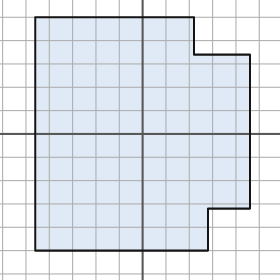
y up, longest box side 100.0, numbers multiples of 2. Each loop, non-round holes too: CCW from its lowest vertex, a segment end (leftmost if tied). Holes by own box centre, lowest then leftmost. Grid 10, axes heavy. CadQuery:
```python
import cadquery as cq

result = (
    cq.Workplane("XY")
    .moveTo(-46.0, -50.0)
    .lineTo(28.0, -50.0)
    .lineTo(28.0, -32.0)
    .lineTo(46.0, -32.0)
    .lineTo(46.0, 34.0)
    .lineTo(22.0, 34.0)
    .lineTo(22.0, 50.0)
    .lineTo(-46.0, 50.0)
    .close()
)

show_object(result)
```